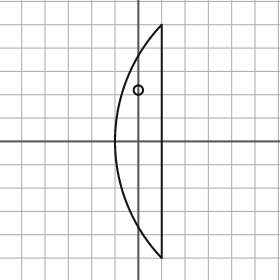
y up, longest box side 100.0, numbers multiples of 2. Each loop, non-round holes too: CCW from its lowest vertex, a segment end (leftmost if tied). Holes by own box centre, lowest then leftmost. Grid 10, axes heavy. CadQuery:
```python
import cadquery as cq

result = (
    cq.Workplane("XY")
    .moveTo(10.0, -50.0)
    .lineTo(10.0, 50.0)
    .threePointArc((-10.0, 0.0), (10.0, -50.0))
    .close()
    .moveTo(0.0, 22.0)
    .circle(2.0)
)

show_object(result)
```